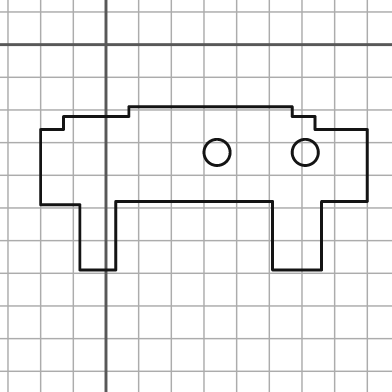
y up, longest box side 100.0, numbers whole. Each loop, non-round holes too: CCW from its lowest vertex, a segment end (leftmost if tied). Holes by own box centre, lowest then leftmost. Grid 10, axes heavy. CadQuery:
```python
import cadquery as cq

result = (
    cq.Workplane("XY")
    .moveTo(-8.0, -69.0)
    .lineTo(3.0, -69.0)
    .lineTo(3.0, -48.0)
    .lineTo(51.0, -48.0)
    .lineTo(51.0, -69.0)
    .lineTo(66.0, -69.0)
    .lineTo(66.0, -48.0)
    .lineTo(80.0, -48.0)
    .lineTo(80.0, -26.0)
    .lineTo(64.0, -26.0)
    .lineTo(64.0, -22.0)
    .lineTo(57.0, -22.0)
    .lineTo(57.0, -19.0)
    .lineTo(7.0, -19.0)
    .lineTo(7.0, -22.0)
    .lineTo(-13.0, -22.0)
    .lineTo(-13.0, -26.0)
    .lineTo(-20.0, -26.0)
    .lineTo(-20.0, -49.0)
    .lineTo(-8.0, -49.0)
    .close()
    .moveTo(34.0, -33.0)
    .circle(4.0)
    .moveTo(61.0, -33.0)
    .circle(4.0)
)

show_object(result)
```